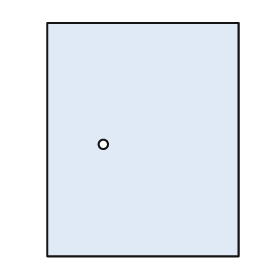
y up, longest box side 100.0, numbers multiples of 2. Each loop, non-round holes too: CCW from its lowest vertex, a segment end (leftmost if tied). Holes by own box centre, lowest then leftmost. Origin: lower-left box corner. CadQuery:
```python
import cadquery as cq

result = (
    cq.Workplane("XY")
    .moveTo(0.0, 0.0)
    .lineTo(82.0, 0.0)
    .lineTo(82.0, 100.0)
    .lineTo(0.0, 100.0)
    .close()
    .moveTo(24.0, 48.0)
    .circle(2.0)
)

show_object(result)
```